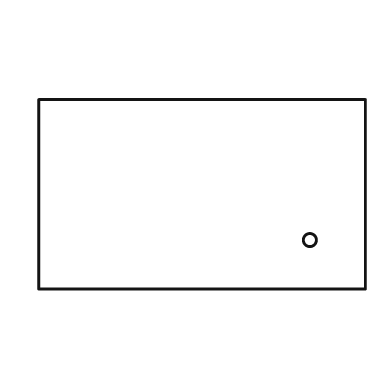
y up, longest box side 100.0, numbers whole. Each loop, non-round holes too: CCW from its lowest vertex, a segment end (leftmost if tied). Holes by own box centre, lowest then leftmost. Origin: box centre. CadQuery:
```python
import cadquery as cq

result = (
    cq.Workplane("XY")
    .moveTo(-50.0, -29.0)
    .lineTo(50.0, -29.0)
    .lineTo(50.0, 29.0)
    .lineTo(-50.0, 29.0)
    .close()
    .moveTo(33.0, -14.0)
    .circle(2.0)
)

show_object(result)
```